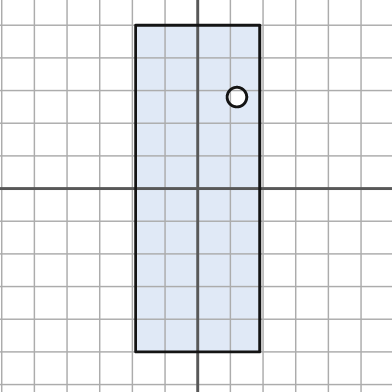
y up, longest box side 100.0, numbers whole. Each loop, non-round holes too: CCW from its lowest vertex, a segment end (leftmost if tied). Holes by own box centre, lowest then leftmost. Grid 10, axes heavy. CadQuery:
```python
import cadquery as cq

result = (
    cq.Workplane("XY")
    .moveTo(-19.0, -50.0)
    .lineTo(19.0, -50.0)
    .lineTo(19.0, 50.0)
    .lineTo(-19.0, 50.0)
    .close()
    .moveTo(12.0, 28.0)
    .circle(3.0)
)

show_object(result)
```